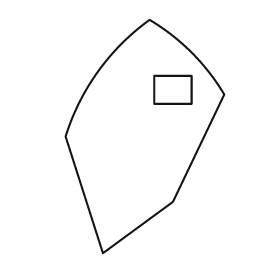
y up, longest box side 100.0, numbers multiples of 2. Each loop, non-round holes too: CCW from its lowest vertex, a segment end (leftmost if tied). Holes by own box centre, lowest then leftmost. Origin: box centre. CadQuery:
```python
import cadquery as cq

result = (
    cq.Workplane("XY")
    .moveTo(-18.0, -50.0)
    .lineTo(12.0, -28.0)
    .lineTo(34.0, 18.0)
    .threePointArc((20.0, 36.0), (2.0, 50.0))
    .threePointArc((-20.0, 28.0), (-34.0, 0.0))
    .close()
    .moveTo(4.0, 14.0)
    .lineTo(20.0, 14.0)
    .lineTo(20.0, 26.0)
    .lineTo(4.0, 26.0)
    .close()
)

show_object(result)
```